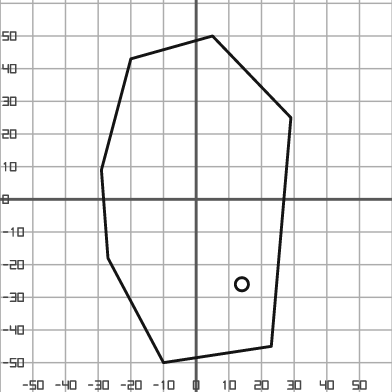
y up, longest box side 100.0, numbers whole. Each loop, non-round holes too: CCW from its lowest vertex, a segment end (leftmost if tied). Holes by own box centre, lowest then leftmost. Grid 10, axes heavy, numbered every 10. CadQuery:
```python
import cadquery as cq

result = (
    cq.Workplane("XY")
    .moveTo(-10.0, -50.0)
    .lineTo(23.0, -45.0)
    .lineTo(29.0, 25.0)
    .lineTo(5.0, 50.0)
    .lineTo(-20.0, 43.0)
    .lineTo(-29.0, 9.0)
    .lineTo(-27.0, -18.0)
    .close()
    .moveTo(14.0, -26.0)
    .circle(2.0)
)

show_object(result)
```